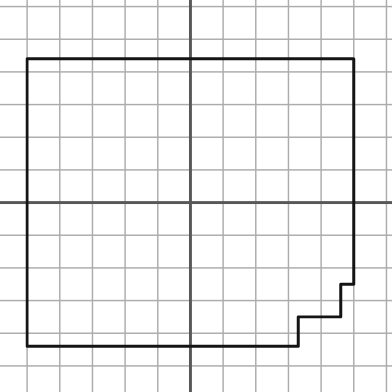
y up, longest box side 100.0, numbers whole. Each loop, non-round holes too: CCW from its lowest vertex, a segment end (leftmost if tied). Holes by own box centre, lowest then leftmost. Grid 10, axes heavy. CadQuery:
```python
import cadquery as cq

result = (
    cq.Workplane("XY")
    .moveTo(-50.0, -44.0)
    .lineTo(33.0, -44.0)
    .lineTo(33.0, -35.0)
    .lineTo(46.0, -35.0)
    .lineTo(46.0, -25.0)
    .lineTo(50.0, -25.0)
    .lineTo(50.0, 44.0)
    .lineTo(-50.0, 44.0)
    .close()
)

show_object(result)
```